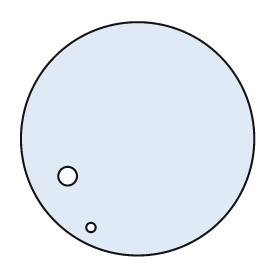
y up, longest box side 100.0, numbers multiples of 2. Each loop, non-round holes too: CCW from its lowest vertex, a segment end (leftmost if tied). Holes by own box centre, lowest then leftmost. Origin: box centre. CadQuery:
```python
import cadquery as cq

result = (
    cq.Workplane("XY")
    .moveTo(0.0, 0.0)
    .circle(50.0)
    .moveTo(-20.0, -38.0)
    .circle(2.0)
    .moveTo(-30.0, -16.0)
    .circle(4.0)
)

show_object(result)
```